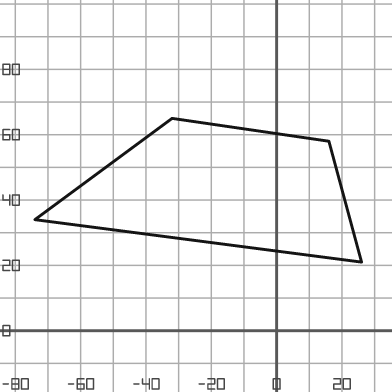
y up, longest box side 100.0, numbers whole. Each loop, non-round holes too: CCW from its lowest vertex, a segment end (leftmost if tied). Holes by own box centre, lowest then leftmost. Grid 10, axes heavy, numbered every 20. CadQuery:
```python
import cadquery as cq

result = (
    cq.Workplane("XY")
    .moveTo(26.0, 21.0)
    .lineTo(16.0, 58.0)
    .lineTo(-32.0, 65.0)
    .lineTo(-74.0, 34.0)
    .close()
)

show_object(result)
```